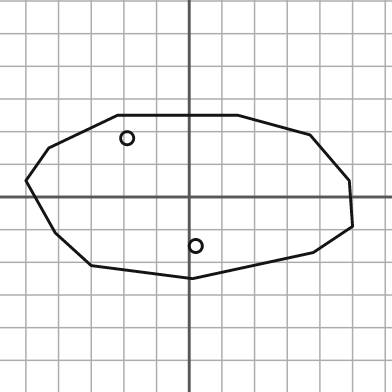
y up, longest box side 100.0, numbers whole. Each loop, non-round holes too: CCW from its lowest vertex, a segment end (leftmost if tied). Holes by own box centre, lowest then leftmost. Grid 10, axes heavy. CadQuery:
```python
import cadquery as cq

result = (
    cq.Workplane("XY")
    .moveTo(1.0, -25.0)
    .lineTo(38.0, -17.0)
    .lineTo(50.0, -9.0)
    .lineTo(49.0, 5.0)
    .lineTo(37.0, 19.0)
    .lineTo(15.0, 25.0)
    .lineTo(-22.0, 25.0)
    .lineTo(-43.0, 15.0)
    .lineTo(-50.0, 5.0)
    .lineTo(-41.0, -11.0)
    .lineTo(-30.0, -21.0)
    .close()
    .moveTo(2.0, -15.0)
    .circle(2.0)
    .moveTo(-19.0, 18.0)
    .circle(2.0)
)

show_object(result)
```